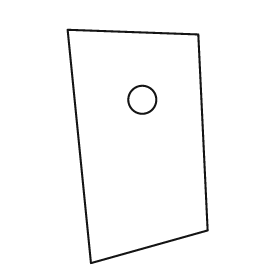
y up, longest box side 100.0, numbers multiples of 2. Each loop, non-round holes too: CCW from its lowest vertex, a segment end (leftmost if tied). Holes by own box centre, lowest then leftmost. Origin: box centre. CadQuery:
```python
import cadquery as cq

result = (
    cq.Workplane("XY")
    .moveTo(-20.0, -50.0)
    .lineTo(30.0, -36.0)
    .lineTo(26.0, 48.0)
    .lineTo(-30.0, 50.0)
    .close()
    .moveTo(2.0, 20.0)
    .circle(6.0)
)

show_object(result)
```